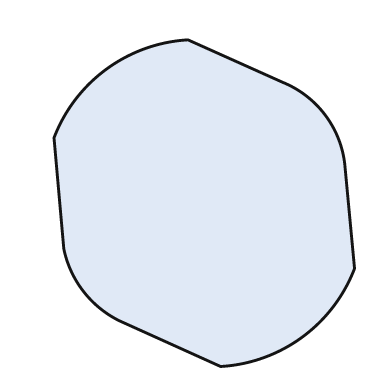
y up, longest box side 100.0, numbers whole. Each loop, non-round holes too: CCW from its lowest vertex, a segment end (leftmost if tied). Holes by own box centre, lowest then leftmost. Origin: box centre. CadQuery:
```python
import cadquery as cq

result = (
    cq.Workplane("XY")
    .moveTo(5.0, -50.0)
    .threePointArc((30.0, -41.0), (46.0, -20.0))
    .lineTo(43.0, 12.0)
    .threePointArc((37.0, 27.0), (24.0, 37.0))
    .lineTo(-5.0, 50.0)
    .threePointArc((-30.0, 41.0), (-46.0, 20.0))
    .lineTo(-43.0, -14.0)
    .threePointArc((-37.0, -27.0), (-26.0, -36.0))
    .close()
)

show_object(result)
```